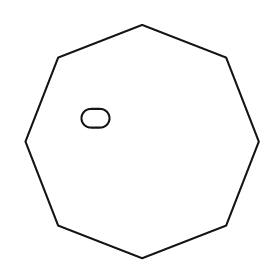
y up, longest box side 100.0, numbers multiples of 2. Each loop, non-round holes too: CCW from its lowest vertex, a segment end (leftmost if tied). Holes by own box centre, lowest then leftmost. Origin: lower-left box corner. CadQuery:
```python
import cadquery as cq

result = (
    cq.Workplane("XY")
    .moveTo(50.0, 0.0)
    .lineTo(86.0, 14.0)
    .lineTo(100.0, 50.0)
    .lineTo(86.0, 86.0)
    .lineTo(50.0, 100.0)
    .lineTo(14.0, 86.0)
    .lineTo(0.0, 50.0)
    .lineTo(14.0, 14.0)
    .close()
    .moveTo(28.0, 56.0)
    .lineTo(32.0, 56.0)
    .threePointArc((36.0, 60.0), (32.0, 64.0))
    .lineTo(28.0, 64.0)
    .threePointArc((24.0, 60.0), (28.0, 56.0))
    .close()
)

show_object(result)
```